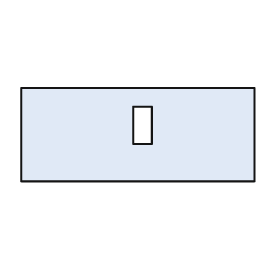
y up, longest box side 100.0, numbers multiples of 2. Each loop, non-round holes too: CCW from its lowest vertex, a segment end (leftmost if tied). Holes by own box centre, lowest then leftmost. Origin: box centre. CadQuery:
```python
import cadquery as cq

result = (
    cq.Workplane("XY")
    .moveTo(-50.0, -20.0)
    .lineTo(50.0, -20.0)
    .lineTo(50.0, 20.0)
    .lineTo(-50.0, 20.0)
    .close()
    .moveTo(-2.0, -4.0)
    .lineTo(6.0, -4.0)
    .lineTo(6.0, 12.0)
    .lineTo(-2.0, 12.0)
    .close()
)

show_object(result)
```